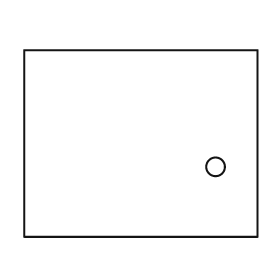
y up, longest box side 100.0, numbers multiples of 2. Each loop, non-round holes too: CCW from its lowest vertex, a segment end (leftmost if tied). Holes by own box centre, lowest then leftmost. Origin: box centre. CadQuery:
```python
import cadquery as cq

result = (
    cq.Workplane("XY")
    .moveTo(-50.0, -40.0)
    .lineTo(50.0, -40.0)
    .lineTo(50.0, 40.0)
    .lineTo(-50.0, 40.0)
    .close()
    .moveTo(32.0, -10.0)
    .circle(4.0)
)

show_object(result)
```